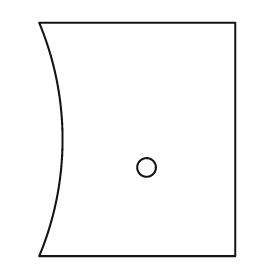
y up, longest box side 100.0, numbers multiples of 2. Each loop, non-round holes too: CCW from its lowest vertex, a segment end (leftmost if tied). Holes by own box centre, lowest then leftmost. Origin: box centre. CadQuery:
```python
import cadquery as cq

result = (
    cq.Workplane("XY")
    .moveTo(-42.0, -50.0)
    .lineTo(42.0, -50.0)
    .lineTo(42.0, 50.0)
    .lineTo(-42.0, 50.0)
    .threePointArc((-32.0, 0.0), (-42.0, -50.0))
    .close()
    .moveTo(4.0, -12.0)
    .circle(4.0)
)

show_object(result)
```